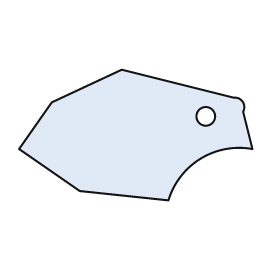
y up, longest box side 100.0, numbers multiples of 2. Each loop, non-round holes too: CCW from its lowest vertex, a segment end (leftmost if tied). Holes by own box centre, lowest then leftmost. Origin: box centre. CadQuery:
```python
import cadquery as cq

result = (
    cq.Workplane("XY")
    .moveTo(14.0, -28.0)
    .threePointArc((28.0, -10.0), (50.0, -6.0))
    .lineTo(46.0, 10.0)
    .threePointArc((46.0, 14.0), (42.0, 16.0))
    .lineTo(-6.0, 28.0)
    .lineTo(-36.0, 14.0)
    .lineTo(-50.0, -6.0)
    .lineTo(-24.0, -24.0)
    .close()
    .moveTo(30.0, 8.0)
    .circle(4.0)
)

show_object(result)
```